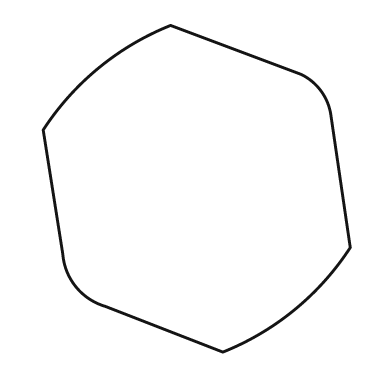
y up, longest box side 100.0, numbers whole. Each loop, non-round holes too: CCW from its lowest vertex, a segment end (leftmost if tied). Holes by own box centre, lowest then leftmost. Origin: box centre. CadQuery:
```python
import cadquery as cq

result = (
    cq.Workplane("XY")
    .moveTo(8.0, -50.0)
    .threePointArc((30.0, -37.0), (47.0, -18.0))
    .lineTo(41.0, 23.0)
    .threePointArc((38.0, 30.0), (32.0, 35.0))
    .lineTo(-8.0, 50.0)
    .threePointArc((-30.0, 37.0), (-47.0, 18.0))
    .lineTo(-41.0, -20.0)
    .threePointArc((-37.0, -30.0), (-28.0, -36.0))
    .close()
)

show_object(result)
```